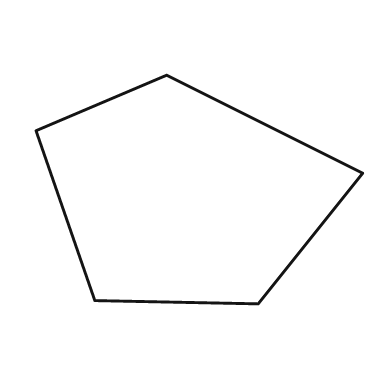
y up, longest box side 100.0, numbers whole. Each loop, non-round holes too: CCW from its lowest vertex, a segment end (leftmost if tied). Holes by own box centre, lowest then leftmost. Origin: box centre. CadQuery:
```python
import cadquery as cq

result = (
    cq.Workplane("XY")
    .moveTo(18.0, -35.0)
    .lineTo(50.0, 5.0)
    .lineTo(-10.0, 35.0)
    .lineTo(-50.0, 18.0)
    .lineTo(-32.0, -34.0)
    .close()
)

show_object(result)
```